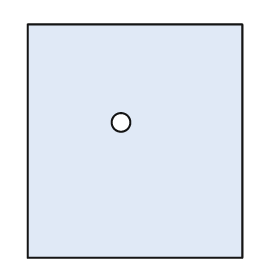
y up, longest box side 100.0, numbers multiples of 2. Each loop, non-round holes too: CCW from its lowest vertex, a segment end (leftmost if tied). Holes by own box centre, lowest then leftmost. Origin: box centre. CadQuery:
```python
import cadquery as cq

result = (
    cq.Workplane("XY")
    .moveTo(-46.0, -50.0)
    .lineTo(46.0, -50.0)
    .lineTo(46.0, 50.0)
    .lineTo(-46.0, 50.0)
    .close()
    .moveTo(-6.0, 8.0)
    .circle(4.0)
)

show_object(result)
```